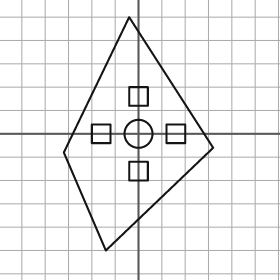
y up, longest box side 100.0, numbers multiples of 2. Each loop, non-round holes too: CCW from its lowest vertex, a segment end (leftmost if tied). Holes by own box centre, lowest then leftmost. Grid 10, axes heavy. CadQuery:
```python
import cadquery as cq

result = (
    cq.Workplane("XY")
    .moveTo(-14.0, -50.0)
    .lineTo(32.0, -6.0)
    .lineTo(-4.0, 50.0)
    .lineTo(-32.0, -8.0)
    .close()
    .moveTo(-4.0, -20.0)
    .lineTo(4.0, -20.0)
    .lineTo(4.0, -12.0)
    .lineTo(-4.0, -12.0)
    .close()
    .moveTo(-20.0, -4.0)
    .lineTo(-12.0, -4.0)
    .lineTo(-12.0, 4.0)
    .lineTo(-20.0, 4.0)
    .close()
    .moveTo(0.0, 0.0)
    .circle(6.0)
    .moveTo(12.0, -4.0)
    .lineTo(20.0, -4.0)
    .lineTo(20.0, 4.0)
    .lineTo(12.0, 4.0)
    .close()
    .moveTo(-4.0, 12.0)
    .lineTo(4.0, 12.0)
    .lineTo(4.0, 20.0)
    .lineTo(-4.0, 20.0)
    .close()
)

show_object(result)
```